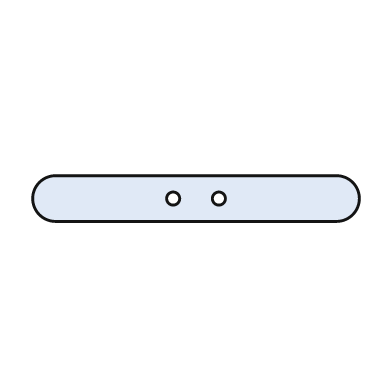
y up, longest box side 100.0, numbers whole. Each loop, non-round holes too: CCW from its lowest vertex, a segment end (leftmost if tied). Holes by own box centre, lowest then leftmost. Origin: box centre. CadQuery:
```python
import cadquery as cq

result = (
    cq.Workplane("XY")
    .moveTo(-43.0, -7.0)
    .lineTo(43.0, -7.0)
    .threePointArc((50.0, 0.0), (43.0, 7.0))
    .lineTo(-43.0, 7.0)
    .threePointArc((-50.0, 0.0), (-43.0, -7.0))
    .close()
    .moveTo(-7.0, 0.0)
    .circle(2.0)
    .moveTo(7.0, 0.0)
    .circle(2.0)
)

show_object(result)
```